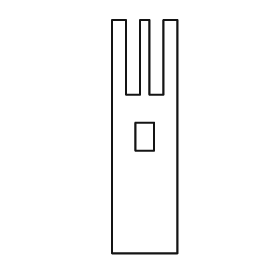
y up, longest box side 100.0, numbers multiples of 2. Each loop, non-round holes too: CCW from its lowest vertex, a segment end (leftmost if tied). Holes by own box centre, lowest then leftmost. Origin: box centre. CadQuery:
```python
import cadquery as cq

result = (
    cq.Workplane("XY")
    .moveTo(-14.0, -50.0)
    .lineTo(14.0, -50.0)
    .lineTo(14.0, 50.0)
    .lineTo(8.0, 50.0)
    .lineTo(8.0, 18.0)
    .lineTo(2.0, 18.0)
    .lineTo(2.0, 50.0)
    .lineTo(-2.0, 50.0)
    .lineTo(-2.0, 18.0)
    .lineTo(-8.0, 18.0)
    .lineTo(-8.0, 50.0)
    .lineTo(-14.0, 50.0)
    .close()
    .moveTo(-4.0, -6.0)
    .lineTo(4.0, -6.0)
    .lineTo(4.0, 6.0)
    .lineTo(-4.0, 6.0)
    .close()
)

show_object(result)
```